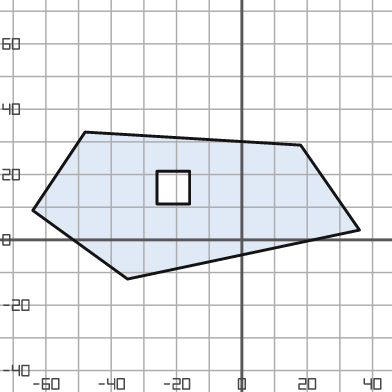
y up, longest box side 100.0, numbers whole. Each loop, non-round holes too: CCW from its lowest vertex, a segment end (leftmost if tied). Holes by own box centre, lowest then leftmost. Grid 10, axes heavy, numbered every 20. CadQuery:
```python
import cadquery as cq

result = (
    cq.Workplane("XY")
    .moveTo(-35.0, -12.0)
    .lineTo(36.0, 3.0)
    .lineTo(18.0, 29.0)
    .lineTo(-48.0, 33.0)
    .lineTo(-64.0, 9.0)
    .close()
    .moveTo(-26.0, 11.0)
    .lineTo(-16.0, 11.0)
    .lineTo(-16.0, 21.0)
    .lineTo(-26.0, 21.0)
    .close()
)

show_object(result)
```